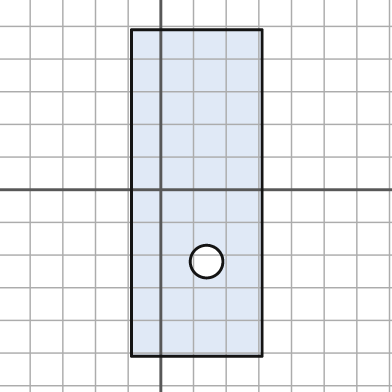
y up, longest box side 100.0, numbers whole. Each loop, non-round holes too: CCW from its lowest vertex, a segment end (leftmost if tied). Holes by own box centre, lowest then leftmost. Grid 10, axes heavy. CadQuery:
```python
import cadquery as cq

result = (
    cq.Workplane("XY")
    .moveTo(-9.0, -51.0)
    .lineTo(31.0, -51.0)
    .lineTo(31.0, 49.0)
    .lineTo(-9.0, 49.0)
    .close()
    .moveTo(14.0, -22.0)
    .circle(5.0)
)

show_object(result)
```